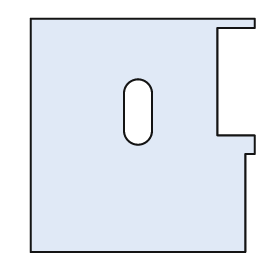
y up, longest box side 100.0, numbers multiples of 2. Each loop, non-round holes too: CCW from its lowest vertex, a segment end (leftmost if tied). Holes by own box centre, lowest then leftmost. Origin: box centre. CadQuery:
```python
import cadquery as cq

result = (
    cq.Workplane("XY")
    .moveTo(-48.0, -50.0)
    .lineTo(44.0, -50.0)
    .lineTo(44.0, -8.0)
    .lineTo(48.0, -8.0)
    .lineTo(48.0, 0.0)
    .lineTo(32.0, 0.0)
    .lineTo(32.0, 46.0)
    .lineTo(48.0, 46.0)
    .lineTo(48.0, 50.0)
    .lineTo(-48.0, 50.0)
    .close()
    .moveTo(-8.0, 2.0)
    .threePointArc((-2.0, -4.0), (4.0, 2.0))
    .lineTo(4.0, 18.0)
    .threePointArc((-2.0, 24.0), (-8.0, 18.0))
    .close()
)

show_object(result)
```